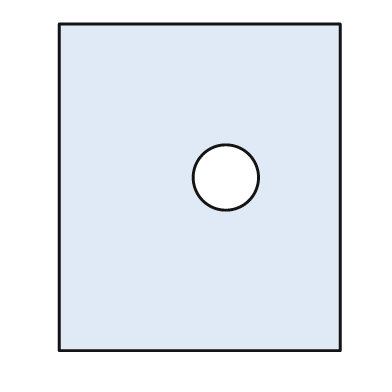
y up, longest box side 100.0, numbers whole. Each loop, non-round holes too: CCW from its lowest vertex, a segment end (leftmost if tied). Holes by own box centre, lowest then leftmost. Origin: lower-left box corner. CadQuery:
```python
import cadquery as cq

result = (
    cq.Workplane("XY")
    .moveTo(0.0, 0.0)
    .lineTo(86.0, 0.0)
    .lineTo(86.0, 100.0)
    .lineTo(0.0, 100.0)
    .close()
    .moveTo(51.0, 53.0)
    .circle(10.0)
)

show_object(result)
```